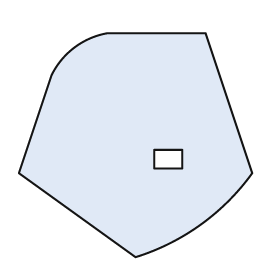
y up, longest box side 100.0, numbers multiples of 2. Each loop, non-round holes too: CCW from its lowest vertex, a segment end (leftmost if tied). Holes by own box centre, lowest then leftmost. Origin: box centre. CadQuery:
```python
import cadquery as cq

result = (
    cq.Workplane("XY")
    .moveTo(0.0, -48.0)
    .threePointArc((28.0, -34.0), (50.0, -12.0))
    .lineTo(30.0, 48.0)
    .lineTo(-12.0, 48.0)
    .threePointArc((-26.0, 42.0), (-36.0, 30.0))
    .lineTo(-50.0, -12.0)
    .close()
    .moveTo(8.0, -10.0)
    .lineTo(20.0, -10.0)
    .lineTo(20.0, -2.0)
    .lineTo(8.0, -2.0)
    .close()
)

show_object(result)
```